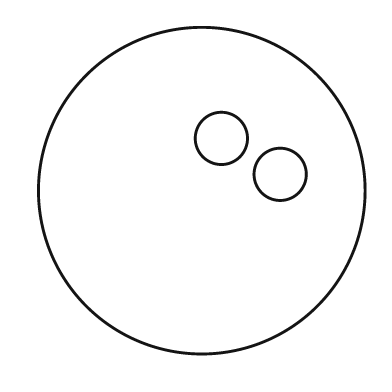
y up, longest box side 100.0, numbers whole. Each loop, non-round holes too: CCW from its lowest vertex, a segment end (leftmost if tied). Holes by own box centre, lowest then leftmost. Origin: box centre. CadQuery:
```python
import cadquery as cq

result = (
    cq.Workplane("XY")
    .moveTo(0.0, 0.0)
    .circle(50.0)
    .moveTo(24.0, 5.0)
    .circle(8.0)
    .moveTo(6.0, 16.0)
    .circle(8.0)
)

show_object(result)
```